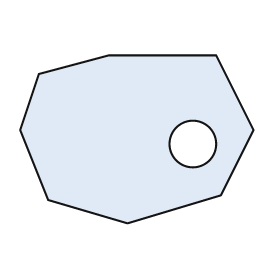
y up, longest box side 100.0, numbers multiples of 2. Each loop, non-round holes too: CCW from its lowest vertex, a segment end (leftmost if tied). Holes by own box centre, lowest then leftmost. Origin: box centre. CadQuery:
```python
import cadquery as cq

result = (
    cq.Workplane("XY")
    .moveTo(-4.0, -36.0)
    .lineTo(36.0, -24.0)
    .lineTo(50.0, 4.0)
    .lineTo(34.0, 36.0)
    .lineTo(-12.0, 36.0)
    .lineTo(-42.0, 28.0)
    .lineTo(-50.0, 4.0)
    .lineTo(-38.0, -26.0)
    .close()
    .moveTo(24.0, -2.0)
    .circle(10.0)
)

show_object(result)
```